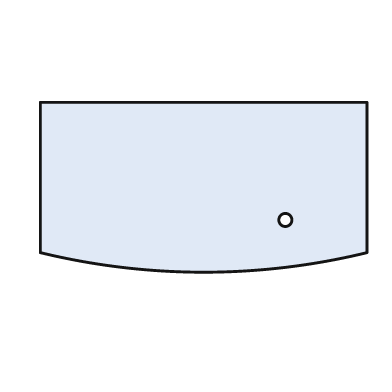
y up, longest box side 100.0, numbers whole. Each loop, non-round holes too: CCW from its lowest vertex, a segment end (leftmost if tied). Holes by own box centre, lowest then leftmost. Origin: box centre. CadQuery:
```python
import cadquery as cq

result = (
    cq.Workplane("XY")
    .moveTo(-50.0, -20.0)
    .threePointArc((0.0, -26.0), (50.0, -20.0))
    .lineTo(50.0, 26.0)
    .lineTo(-50.0, 26.0)
    .close()
    .moveTo(25.0, -10.0)
    .circle(2.0)
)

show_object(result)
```